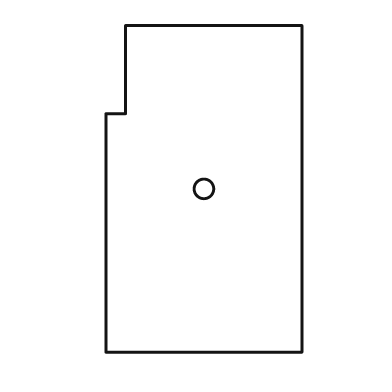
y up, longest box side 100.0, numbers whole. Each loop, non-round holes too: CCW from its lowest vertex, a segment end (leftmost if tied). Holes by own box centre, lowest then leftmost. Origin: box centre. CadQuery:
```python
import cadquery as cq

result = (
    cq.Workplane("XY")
    .moveTo(-30.0, -50.0)
    .lineTo(30.0, -50.0)
    .lineTo(30.0, 50.0)
    .lineTo(-24.0, 50.0)
    .lineTo(-24.0, 23.0)
    .lineTo(-30.0, 23.0)
    .close()
    .moveTo(0.0, 0.0)
    .circle(3.0)
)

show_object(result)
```